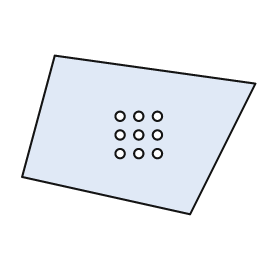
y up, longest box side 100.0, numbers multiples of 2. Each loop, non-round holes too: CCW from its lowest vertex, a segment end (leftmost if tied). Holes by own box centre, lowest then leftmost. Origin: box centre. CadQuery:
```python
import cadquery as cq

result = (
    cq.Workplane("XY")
    .moveTo(22.0, -34.0)
    .lineTo(50.0, 22.0)
    .lineTo(-36.0, 34.0)
    .lineTo(-50.0, -18.0)
    .close()
    .moveTo(-8.0, -8.0)
    .circle(2.0)
    .moveTo(0.0, -8.0)
    .circle(2.0)
    .moveTo(8.0, -8.0)
    .circle(2.0)
    .moveTo(-8.0, 0.0)
    .circle(2.0)
    .moveTo(0.0, 0.0)
    .circle(2.0)
    .moveTo(8.0, 0.0)
    .circle(2.0)
    .moveTo(-8.0, 8.0)
    .circle(2.0)
    .moveTo(0.0, 8.0)
    .circle(2.0)
    .moveTo(8.0, 8.0)
    .circle(2.0)
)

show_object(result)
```